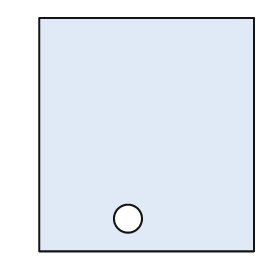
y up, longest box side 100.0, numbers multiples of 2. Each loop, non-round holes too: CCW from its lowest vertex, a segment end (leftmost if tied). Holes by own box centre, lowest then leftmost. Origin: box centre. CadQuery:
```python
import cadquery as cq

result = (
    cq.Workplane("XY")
    .moveTo(-46.0, -50.0)
    .lineTo(46.0, -50.0)
    .lineTo(46.0, 50.0)
    .lineTo(-46.0, 50.0)
    .close()
    .moveTo(-8.0, -36.0)
    .circle(6.0)
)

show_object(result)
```